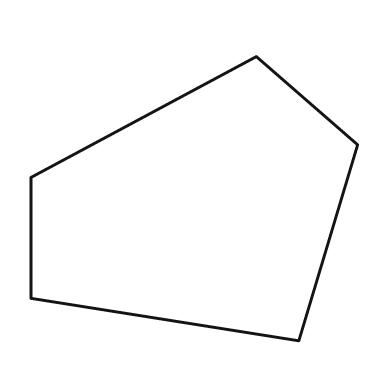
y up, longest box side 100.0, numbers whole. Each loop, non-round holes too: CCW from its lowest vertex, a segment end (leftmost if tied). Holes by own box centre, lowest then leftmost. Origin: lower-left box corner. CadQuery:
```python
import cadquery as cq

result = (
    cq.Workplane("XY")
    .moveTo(82.0, 0.0)
    .lineTo(100.0, 60.0)
    .lineTo(69.0, 87.0)
    .lineTo(0.0, 50.0)
    .lineTo(0.0, 13.0)
    .close()
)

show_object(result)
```